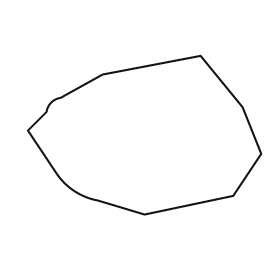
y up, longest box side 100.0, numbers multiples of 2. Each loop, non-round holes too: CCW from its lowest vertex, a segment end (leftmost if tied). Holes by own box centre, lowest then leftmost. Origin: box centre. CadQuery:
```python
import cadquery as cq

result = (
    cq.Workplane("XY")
    .moveTo(0.0, -34.0)
    .lineTo(38.0, -26.0)
    .lineTo(50.0, -8.0)
    .lineTo(42.0, 12.0)
    .lineTo(24.0, 34.0)
    .lineTo(-18.0, 26.0)
    .lineTo(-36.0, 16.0)
    .threePointArc((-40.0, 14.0), (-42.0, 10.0))
    .lineTo(-50.0, 2.0)
    .lineTo(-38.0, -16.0)
    .threePointArc((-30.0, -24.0), (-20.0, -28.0))
    .close()
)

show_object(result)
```